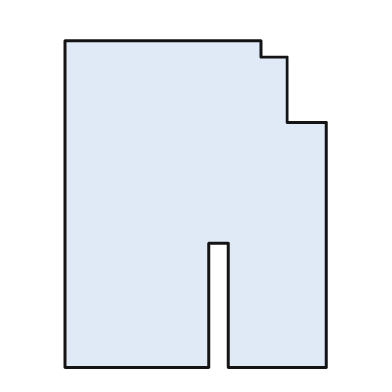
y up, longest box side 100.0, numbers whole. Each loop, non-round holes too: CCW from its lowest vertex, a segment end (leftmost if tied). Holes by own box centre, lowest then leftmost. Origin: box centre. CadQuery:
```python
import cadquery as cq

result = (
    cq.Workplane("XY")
    .moveTo(-40.0, -50.0)
    .lineTo(4.0, -50.0)
    .lineTo(4.0, -12.0)
    .lineTo(10.0, -12.0)
    .lineTo(10.0, -50.0)
    .lineTo(40.0, -50.0)
    .lineTo(40.0, 25.0)
    .lineTo(28.0, 25.0)
    .lineTo(28.0, 45.0)
    .lineTo(20.0, 45.0)
    .lineTo(20.0, 50.0)
    .lineTo(-40.0, 50.0)
    .close()
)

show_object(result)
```